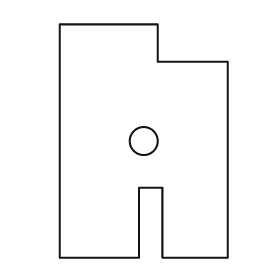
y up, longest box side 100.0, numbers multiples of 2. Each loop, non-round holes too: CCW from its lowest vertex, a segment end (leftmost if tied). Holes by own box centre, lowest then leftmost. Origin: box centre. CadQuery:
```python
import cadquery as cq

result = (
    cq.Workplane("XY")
    .moveTo(-36.0, -50.0)
    .lineTo(-2.0, -50.0)
    .lineTo(-2.0, -20.0)
    .lineTo(8.0, -20.0)
    .lineTo(8.0, -50.0)
    .lineTo(36.0, -50.0)
    .lineTo(36.0, 34.0)
    .lineTo(6.0, 34.0)
    .lineTo(6.0, 50.0)
    .lineTo(-36.0, 50.0)
    .close()
    .moveTo(0.0, 0.0)
    .circle(6.0)
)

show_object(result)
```